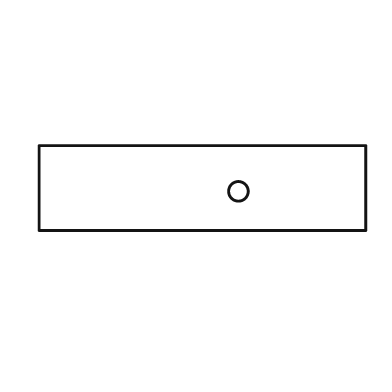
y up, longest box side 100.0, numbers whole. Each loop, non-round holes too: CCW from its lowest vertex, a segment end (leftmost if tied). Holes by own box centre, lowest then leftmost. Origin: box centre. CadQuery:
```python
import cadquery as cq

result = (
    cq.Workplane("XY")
    .moveTo(-50.0, -13.0)
    .lineTo(50.0, -13.0)
    .lineTo(50.0, 13.0)
    .lineTo(-50.0, 13.0)
    .close()
    .moveTo(11.0, -1.0)
    .circle(3.0)
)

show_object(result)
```